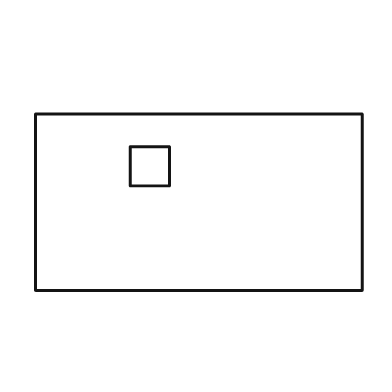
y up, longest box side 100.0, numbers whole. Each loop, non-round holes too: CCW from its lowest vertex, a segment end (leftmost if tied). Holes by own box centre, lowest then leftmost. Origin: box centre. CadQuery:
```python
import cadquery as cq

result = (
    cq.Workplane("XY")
    .moveTo(-50.0, -27.0)
    .lineTo(50.0, -27.0)
    .lineTo(50.0, 27.0)
    .lineTo(-50.0, 27.0)
    .close()
    .moveTo(-21.0, 5.0)
    .lineTo(-9.0, 5.0)
    .lineTo(-9.0, 17.0)
    .lineTo(-21.0, 17.0)
    .close()
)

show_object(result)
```